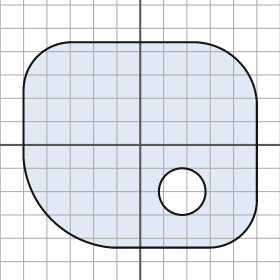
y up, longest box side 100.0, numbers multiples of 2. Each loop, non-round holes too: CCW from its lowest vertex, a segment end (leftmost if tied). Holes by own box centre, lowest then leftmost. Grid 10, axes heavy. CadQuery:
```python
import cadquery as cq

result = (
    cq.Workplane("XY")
    .moveTo(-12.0, -44.0)
    .lineTo(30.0, -44.0)
    .threePointArc((44.0, -38.0), (50.0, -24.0))
    .lineTo(50.0, 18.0)
    .threePointArc((42.0, 36.0), (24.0, 44.0))
    .lineTo(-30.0, 44.0)
    .threePointArc((-44.0, 38.0), (-50.0, 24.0))
    .lineTo(-50.0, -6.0)
    .threePointArc((-38.0, -32.0), (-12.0, -44.0))
    .close()
    .moveTo(18.0, -20.0)
    .circle(10.0)
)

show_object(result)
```